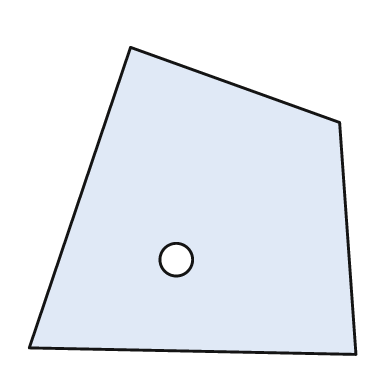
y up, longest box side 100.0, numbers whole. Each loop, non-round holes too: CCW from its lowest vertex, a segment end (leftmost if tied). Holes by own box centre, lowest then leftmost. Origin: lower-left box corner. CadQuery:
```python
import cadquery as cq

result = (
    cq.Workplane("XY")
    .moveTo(100.0, 0.0)
    .lineTo(95.0, 71.0)
    .lineTo(31.0, 94.0)
    .lineTo(0.0, 2.0)
    .close()
    .moveTo(45.0, 29.0)
    .circle(5.0)
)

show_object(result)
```